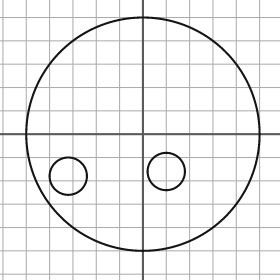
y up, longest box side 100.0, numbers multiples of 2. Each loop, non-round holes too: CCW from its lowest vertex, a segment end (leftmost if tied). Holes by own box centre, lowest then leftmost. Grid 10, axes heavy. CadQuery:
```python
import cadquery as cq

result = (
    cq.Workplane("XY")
    .moveTo(0.0, 0.0)
    .circle(50.0)
    .moveTo(-32.0, -18.0)
    .circle(8.0)
    .moveTo(10.0, -16.0)
    .circle(8.0)
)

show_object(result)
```